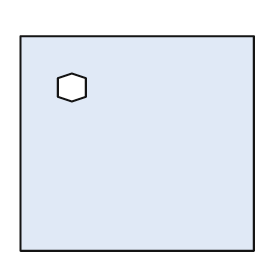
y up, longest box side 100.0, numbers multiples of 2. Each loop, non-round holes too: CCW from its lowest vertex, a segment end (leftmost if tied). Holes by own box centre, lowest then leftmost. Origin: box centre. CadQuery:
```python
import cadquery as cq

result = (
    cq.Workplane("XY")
    .moveTo(-50.0, -46.0)
    .lineTo(50.0, -46.0)
    .lineTo(50.0, 46.0)
    .lineTo(-50.0, 46.0)
    .close()
    .moveTo(-28.0, 18.0)
    .lineTo(-22.0, 20.0)
    .lineTo(-22.0, 28.0)
    .lineTo(-28.0, 30.0)
    .lineTo(-34.0, 28.0)
    .lineTo(-34.0, 20.0)
    .close()
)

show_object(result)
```